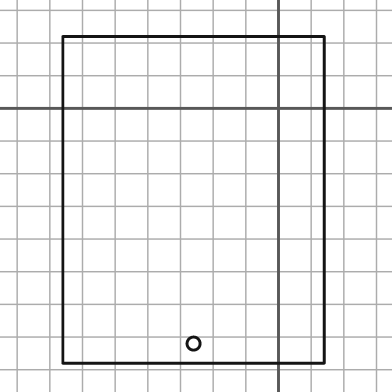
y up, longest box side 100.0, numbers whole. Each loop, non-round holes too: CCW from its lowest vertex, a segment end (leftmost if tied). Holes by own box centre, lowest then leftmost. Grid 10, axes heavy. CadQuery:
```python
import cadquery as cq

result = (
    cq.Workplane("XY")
    .moveTo(-66.0, -78.0)
    .lineTo(14.0, -78.0)
    .lineTo(14.0, 22.0)
    .lineTo(-66.0, 22.0)
    .close()
    .moveTo(-26.0, -72.0)
    .circle(2.0)
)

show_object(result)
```